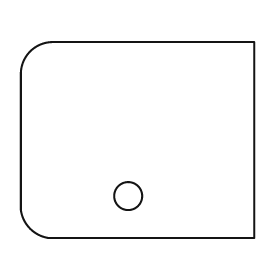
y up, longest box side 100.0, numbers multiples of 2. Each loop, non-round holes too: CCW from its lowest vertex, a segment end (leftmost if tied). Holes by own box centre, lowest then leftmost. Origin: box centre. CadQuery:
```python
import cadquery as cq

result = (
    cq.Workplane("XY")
    .moveTo(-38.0, -42.0)
    .lineTo(50.0, -42.0)
    .lineTo(50.0, 42.0)
    .lineTo(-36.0, 42.0)
    .threePointArc((-46.0, 38.0), (-50.0, 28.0))
    .lineTo(-50.0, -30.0)
    .threePointArc((-46.0, -38.0), (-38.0, -42.0))
    .close()
    .moveTo(-4.0, -24.0)
    .circle(6.0)
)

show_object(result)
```